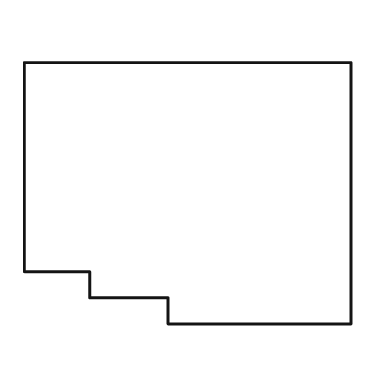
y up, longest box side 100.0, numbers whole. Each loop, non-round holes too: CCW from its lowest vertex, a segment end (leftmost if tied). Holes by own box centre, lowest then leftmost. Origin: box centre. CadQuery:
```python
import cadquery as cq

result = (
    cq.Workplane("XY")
    .moveTo(-6.0, -40.0)
    .lineTo(50.0, -40.0)
    .lineTo(50.0, 40.0)
    .lineTo(-50.0, 40.0)
    .lineTo(-50.0, -24.0)
    .lineTo(-30.0, -24.0)
    .lineTo(-30.0, -32.0)
    .lineTo(-6.0, -32.0)
    .close()
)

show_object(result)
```